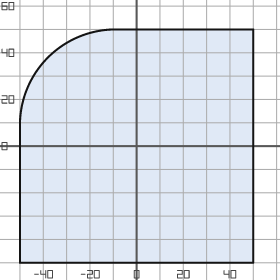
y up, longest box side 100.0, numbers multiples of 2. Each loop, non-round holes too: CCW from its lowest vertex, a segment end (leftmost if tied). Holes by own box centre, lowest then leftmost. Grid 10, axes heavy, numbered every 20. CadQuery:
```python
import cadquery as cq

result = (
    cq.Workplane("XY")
    .moveTo(-50.0, -50.0)
    .lineTo(50.0, -50.0)
    .lineTo(50.0, 50.0)
    .lineTo(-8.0, 50.0)
    .threePointArc((-38.0, 38.0), (-50.0, 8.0))
    .close()
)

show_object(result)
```